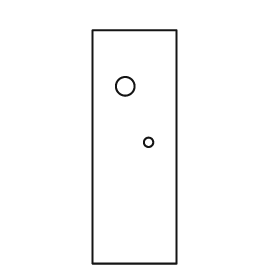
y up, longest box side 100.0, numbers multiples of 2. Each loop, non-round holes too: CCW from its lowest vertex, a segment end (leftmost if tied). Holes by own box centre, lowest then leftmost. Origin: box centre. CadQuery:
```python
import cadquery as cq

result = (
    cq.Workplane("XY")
    .moveTo(-18.0, -50.0)
    .lineTo(18.0, -50.0)
    .lineTo(18.0, 50.0)
    .lineTo(-18.0, 50.0)
    .close()
    .moveTo(6.0, 2.0)
    .circle(2.0)
    .moveTo(-4.0, 26.0)
    .circle(4.0)
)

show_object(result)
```